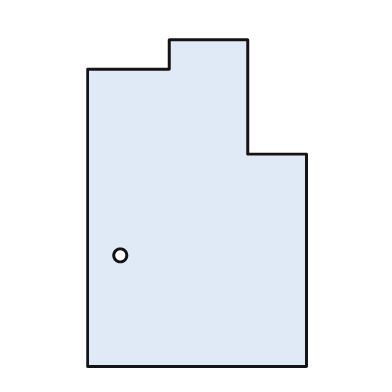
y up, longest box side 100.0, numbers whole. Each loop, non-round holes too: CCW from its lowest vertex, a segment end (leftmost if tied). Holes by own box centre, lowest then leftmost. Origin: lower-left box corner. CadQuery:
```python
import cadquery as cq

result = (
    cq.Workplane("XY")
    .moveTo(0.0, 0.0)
    .lineTo(67.0, 0.0)
    .lineTo(67.0, 65.0)
    .lineTo(49.0, 65.0)
    .lineTo(49.0, 100.0)
    .lineTo(25.0, 100.0)
    .lineTo(25.0, 91.0)
    .lineTo(0.0, 91.0)
    .close()
    .moveTo(10.0, 34.0)
    .circle(2.0)
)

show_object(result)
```